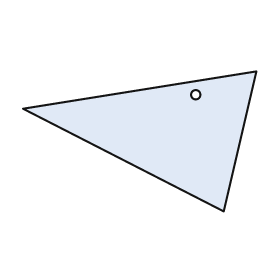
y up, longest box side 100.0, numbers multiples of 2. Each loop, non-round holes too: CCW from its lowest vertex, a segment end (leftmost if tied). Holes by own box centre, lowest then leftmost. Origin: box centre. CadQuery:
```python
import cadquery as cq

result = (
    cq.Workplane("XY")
    .moveTo(36.0, -30.0)
    .lineTo(50.0, 30.0)
    .lineTo(-50.0, 14.0)
    .close()
    .moveTo(24.0, 20.0)
    .circle(2.0)
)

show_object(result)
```